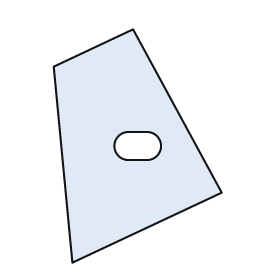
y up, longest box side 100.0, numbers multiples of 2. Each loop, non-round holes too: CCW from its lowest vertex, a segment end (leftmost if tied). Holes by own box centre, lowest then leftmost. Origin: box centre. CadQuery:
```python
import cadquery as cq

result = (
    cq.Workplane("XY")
    .moveTo(-28.0, -50.0)
    .lineTo(36.0, -20.0)
    .lineTo(-2.0, 50.0)
    .lineTo(-36.0, 34.0)
    .close()
    .moveTo(-4.0, -6.0)
    .lineTo(4.0, -6.0)
    .threePointArc((10.0, 0.0), (4.0, 6.0))
    .lineTo(-4.0, 6.0)
    .threePointArc((-10.0, 0.0), (-4.0, -6.0))
    .close()
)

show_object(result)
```